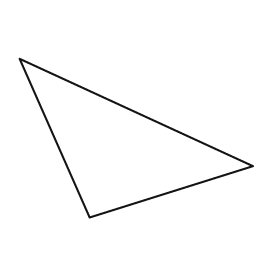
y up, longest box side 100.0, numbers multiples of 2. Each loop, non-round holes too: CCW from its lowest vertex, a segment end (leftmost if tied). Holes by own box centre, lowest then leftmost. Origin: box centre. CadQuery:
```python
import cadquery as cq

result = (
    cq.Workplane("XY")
    .moveTo(-20.0, -34.0)
    .lineTo(50.0, -12.0)
    .lineTo(-50.0, 34.0)
    .close()
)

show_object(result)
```